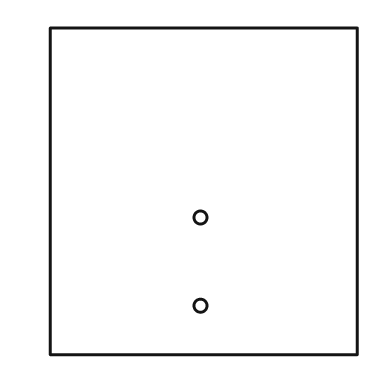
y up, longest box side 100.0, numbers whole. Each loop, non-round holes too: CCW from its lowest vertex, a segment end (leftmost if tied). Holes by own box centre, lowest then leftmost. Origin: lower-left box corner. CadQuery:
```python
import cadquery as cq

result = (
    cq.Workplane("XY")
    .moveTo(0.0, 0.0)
    .lineTo(94.0, 0.0)
    .lineTo(94.0, 100.0)
    .lineTo(0.0, 100.0)
    .close()
    .moveTo(46.0, 15.0)
    .circle(2.0)
    .moveTo(46.0, 42.0)
    .circle(2.0)
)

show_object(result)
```